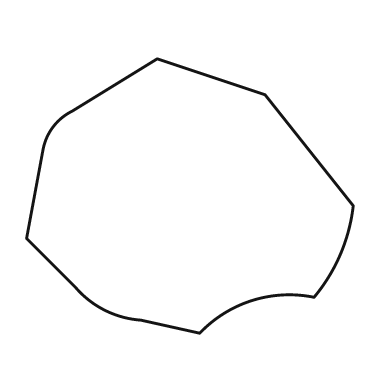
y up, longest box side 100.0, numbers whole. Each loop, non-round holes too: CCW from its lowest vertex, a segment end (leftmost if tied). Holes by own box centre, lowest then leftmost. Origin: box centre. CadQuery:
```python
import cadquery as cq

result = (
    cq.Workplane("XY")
    .moveTo(3.0, -42.0)
    .threePointArc((19.0, -32.0), (38.0, -31.0))
    .threePointArc((46.0, -18.0), (50.0, -3.0))
    .lineTo(23.0, 31.0)
    .lineTo(-10.0, 42.0)
    .lineTo(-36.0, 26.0)
    .threePointArc((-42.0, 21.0), (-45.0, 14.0))
    .lineTo(-50.0, -13.0)
    .lineTo(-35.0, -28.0)
    .threePointArc((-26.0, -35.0), (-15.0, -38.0))
    .close()
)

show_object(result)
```